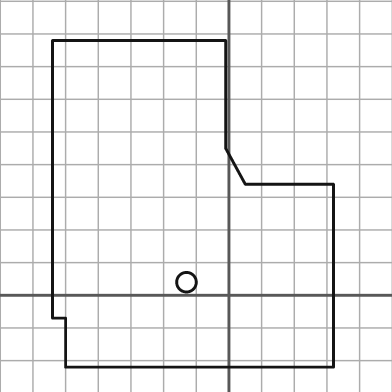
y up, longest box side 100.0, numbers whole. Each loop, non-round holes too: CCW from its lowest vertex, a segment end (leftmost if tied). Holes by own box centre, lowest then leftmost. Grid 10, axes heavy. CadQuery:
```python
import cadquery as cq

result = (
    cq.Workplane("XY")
    .moveTo(-50.0, -22.0)
    .lineTo(32.0, -22.0)
    .lineTo(32.0, 34.0)
    .lineTo(5.0, 34.0)
    .lineTo(-1.0, 45.0)
    .lineTo(-1.0, 78.0)
    .lineTo(-54.0, 78.0)
    .lineTo(-54.0, -7.0)
    .lineTo(-50.0, -7.0)
    .close()
    .moveTo(-13.0, 4.0)
    .circle(3.0)
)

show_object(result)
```